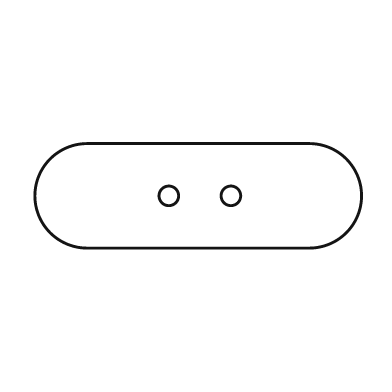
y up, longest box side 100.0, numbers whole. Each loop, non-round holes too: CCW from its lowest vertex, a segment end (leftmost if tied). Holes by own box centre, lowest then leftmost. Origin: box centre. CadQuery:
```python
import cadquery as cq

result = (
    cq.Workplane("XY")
    .moveTo(-34.0, -16.0)
    .lineTo(34.0, -16.0)
    .threePointArc((50.0, 0.0), (34.0, 16.0))
    .lineTo(-34.0, 16.0)
    .threePointArc((-50.0, 0.0), (-34.0, -16.0))
    .close()
    .moveTo(-9.0, 0.0)
    .circle(3.0)
    .moveTo(10.0, 0.0)
    .circle(3.0)
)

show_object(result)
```